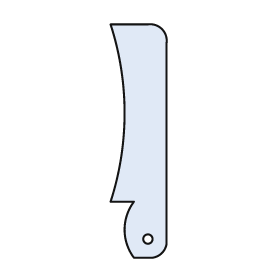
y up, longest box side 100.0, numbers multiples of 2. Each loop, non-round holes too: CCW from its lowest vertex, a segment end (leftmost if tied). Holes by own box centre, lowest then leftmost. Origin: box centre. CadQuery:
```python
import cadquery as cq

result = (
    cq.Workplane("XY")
    .moveTo(-2.0, -50.0)
    .lineTo(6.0, -50.0)
    .threePointArc((10.0, -48.0), (12.0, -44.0))
    .lineTo(12.0, 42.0)
    .threePointArc((10.0, 48.0), (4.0, 50.0))
    .lineTo(-12.0, 50.0)
    .threePointArc((-6.0, 12.0), (-12.0, -26.0))
    .lineTo(-2.0, -26.0)
    .threePointArc((-6.0, -38.0), (-2.0, -50.0))
    .close()
    .moveTo(4.0, -42.0)
    .circle(2.0)
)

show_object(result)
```